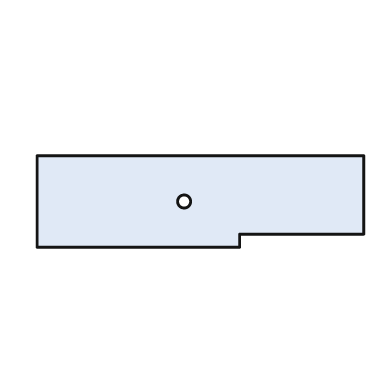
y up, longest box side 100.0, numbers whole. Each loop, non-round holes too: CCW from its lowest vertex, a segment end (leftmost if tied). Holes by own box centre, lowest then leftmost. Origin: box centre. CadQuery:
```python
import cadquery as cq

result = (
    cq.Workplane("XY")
    .moveTo(-50.0, -14.0)
    .lineTo(12.0, -14.0)
    .lineTo(12.0, -10.0)
    .lineTo(50.0, -10.0)
    .lineTo(50.0, 14.0)
    .lineTo(-50.0, 14.0)
    .close()
    .moveTo(-5.0, 0.0)
    .circle(2.0)
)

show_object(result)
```